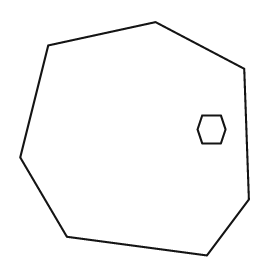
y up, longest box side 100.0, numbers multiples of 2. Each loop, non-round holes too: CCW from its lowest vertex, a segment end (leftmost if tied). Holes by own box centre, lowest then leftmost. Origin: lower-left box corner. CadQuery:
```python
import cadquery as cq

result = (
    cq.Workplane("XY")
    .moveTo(80.0, 0.0)
    .lineTo(98.0, 24.0)
    .lineTo(96.0, 80.0)
    .lineTo(58.0, 100.0)
    .lineTo(12.0, 90.0)
    .lineTo(0.0, 42.0)
    .lineTo(20.0, 8.0)
    .close()
    .moveTo(78.0, 48.0)
    .lineTo(86.0, 48.0)
    .lineTo(88.0, 54.0)
    .lineTo(86.0, 60.0)
    .lineTo(78.0, 60.0)
    .lineTo(76.0, 54.0)
    .close()
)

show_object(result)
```